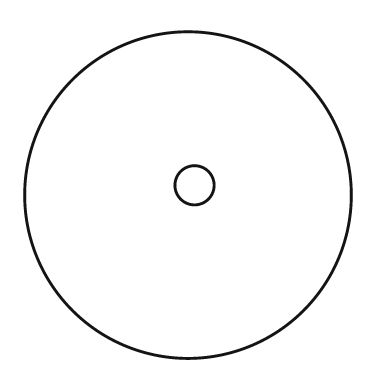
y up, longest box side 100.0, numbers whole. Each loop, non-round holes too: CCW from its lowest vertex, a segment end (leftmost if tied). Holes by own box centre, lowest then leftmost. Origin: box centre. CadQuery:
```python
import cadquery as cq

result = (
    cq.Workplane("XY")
    .moveTo(0.0, 0.0)
    .circle(50.0)
    .moveTo(2.0, 3.0)
    .circle(6.0)
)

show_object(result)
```